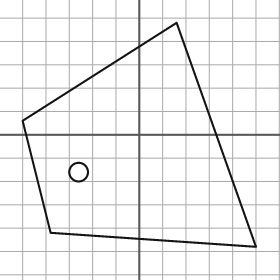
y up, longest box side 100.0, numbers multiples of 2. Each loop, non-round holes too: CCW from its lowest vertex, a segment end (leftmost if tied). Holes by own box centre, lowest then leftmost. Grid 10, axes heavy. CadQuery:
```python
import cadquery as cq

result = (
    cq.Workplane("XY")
    .moveTo(50.0, -48.0)
    .lineTo(16.0, 48.0)
    .lineTo(-50.0, 6.0)
    .lineTo(-38.0, -42.0)
    .close()
    .moveTo(-26.0, -16.0)
    .circle(4.0)
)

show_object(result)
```